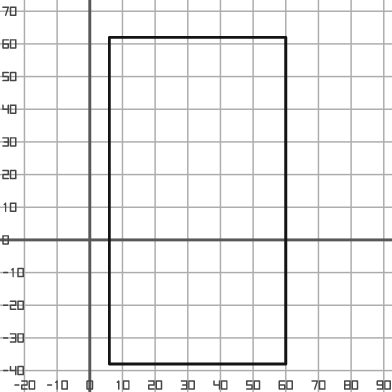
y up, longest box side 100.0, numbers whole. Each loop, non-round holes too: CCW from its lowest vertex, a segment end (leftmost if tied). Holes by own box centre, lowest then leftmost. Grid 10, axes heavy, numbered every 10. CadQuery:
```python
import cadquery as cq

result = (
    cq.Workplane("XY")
    .moveTo(6.0, -38.0)
    .lineTo(60.0, -38.0)
    .lineTo(60.0, 62.0)
    .lineTo(6.0, 62.0)
    .close()
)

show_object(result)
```